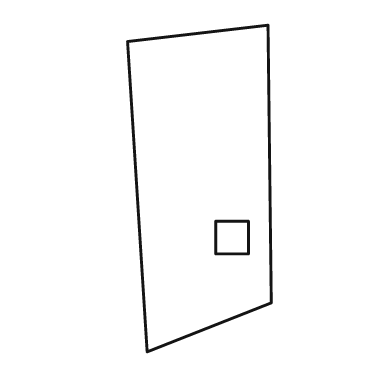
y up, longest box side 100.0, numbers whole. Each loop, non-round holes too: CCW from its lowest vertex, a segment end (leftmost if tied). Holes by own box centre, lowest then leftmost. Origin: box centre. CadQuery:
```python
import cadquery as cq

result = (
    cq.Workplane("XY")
    .moveTo(-16.0, -50.0)
    .lineTo(22.0, -35.0)
    .lineTo(21.0, 50.0)
    .lineTo(-22.0, 45.0)
    .close()
    .moveTo(5.0, -20.0)
    .lineTo(15.0, -20.0)
    .lineTo(15.0, -10.0)
    .lineTo(5.0, -10.0)
    .close()
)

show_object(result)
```